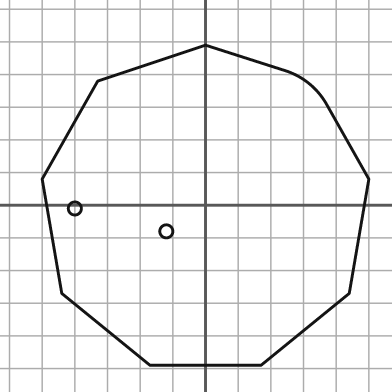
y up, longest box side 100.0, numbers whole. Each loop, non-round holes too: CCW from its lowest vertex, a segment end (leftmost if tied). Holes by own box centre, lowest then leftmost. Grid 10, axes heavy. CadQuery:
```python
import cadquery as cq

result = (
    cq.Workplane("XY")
    .moveTo(-17.0, -49.0)
    .lineTo(17.0, -49.0)
    .lineTo(44.0, -27.0)
    .lineTo(50.0, 8.0)
    .lineTo(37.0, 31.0)
    .threePointArc((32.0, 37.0), (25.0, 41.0))
    .lineTo(0.0, 49.0)
    .lineTo(-33.0, 38.0)
    .lineTo(-50.0, 8.0)
    .lineTo(-44.0, -27.0)
    .close()
    .moveTo(-12.0, -8.0)
    .circle(2.0)
    .moveTo(-40.0, -1.0)
    .circle(2.0)
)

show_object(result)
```